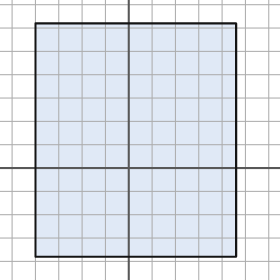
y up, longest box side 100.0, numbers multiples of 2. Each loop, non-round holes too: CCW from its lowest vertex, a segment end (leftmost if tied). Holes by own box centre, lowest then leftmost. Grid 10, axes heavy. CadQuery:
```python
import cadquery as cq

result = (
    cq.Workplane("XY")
    .moveTo(-40.0, -38.0)
    .lineTo(46.0, -38.0)
    .lineTo(46.0, 62.0)
    .lineTo(-40.0, 62.0)
    .close()
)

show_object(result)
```